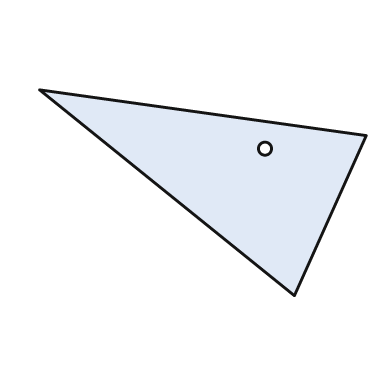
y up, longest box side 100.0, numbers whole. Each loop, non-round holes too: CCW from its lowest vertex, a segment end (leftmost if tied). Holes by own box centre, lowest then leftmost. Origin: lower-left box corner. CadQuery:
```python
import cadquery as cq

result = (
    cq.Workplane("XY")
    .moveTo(78.0, 0.0)
    .lineTo(100.0, 49.0)
    .lineTo(0.0, 63.0)
    .close()
    .moveTo(69.0, 45.0)
    .circle(2.0)
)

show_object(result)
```